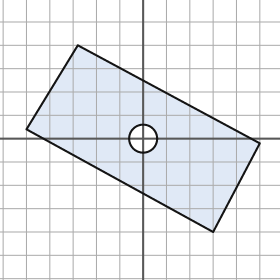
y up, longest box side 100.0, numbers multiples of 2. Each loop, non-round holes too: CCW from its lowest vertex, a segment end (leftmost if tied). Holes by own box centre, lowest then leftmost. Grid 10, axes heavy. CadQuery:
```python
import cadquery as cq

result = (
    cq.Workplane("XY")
    .moveTo(30.0, -40.0)
    .lineTo(50.0, -2.0)
    .lineTo(-28.0, 40.0)
    .lineTo(-50.0, 4.0)
    .close()
    .moveTo(0.0, 0.0)
    .circle(6.0)
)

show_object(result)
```